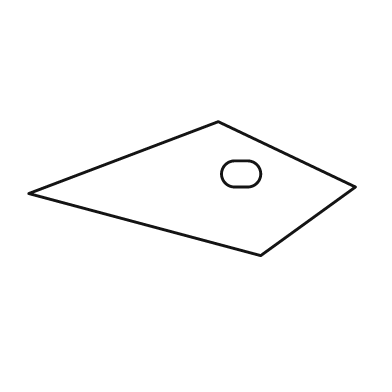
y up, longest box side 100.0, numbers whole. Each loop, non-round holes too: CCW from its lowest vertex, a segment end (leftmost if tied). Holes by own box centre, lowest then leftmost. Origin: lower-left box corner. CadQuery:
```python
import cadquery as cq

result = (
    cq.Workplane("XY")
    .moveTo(71.0, 0.0)
    .lineTo(100.0, 21.0)
    .lineTo(58.0, 41.0)
    .lineTo(0.0, 19.0)
    .close()
    .moveTo(63.0, 21.0)
    .lineTo(67.0, 21.0)
    .threePointArc((71.0, 25.0), (67.0, 29.0))
    .lineTo(63.0, 29.0)
    .threePointArc((59.0, 25.0), (63.0, 21.0))
    .close()
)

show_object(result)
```